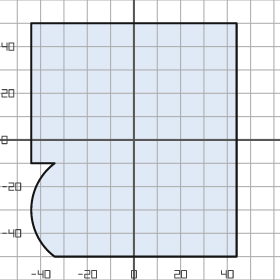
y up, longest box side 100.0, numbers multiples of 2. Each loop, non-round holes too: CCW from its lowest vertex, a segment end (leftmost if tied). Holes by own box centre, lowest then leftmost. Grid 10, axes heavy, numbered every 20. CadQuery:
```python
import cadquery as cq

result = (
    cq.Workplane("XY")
    .moveTo(-34.0, -50.0)
    .lineTo(44.0, -50.0)
    .lineTo(44.0, 50.0)
    .lineTo(-44.0, 50.0)
    .lineTo(-44.0, -10.0)
    .lineTo(-34.0, -10.0)
    .threePointArc((-44.0, -30.0), (-34.0, -50.0))
    .close()
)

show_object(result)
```